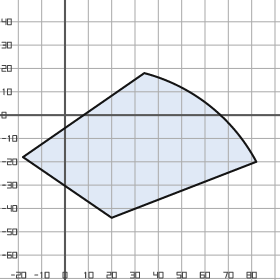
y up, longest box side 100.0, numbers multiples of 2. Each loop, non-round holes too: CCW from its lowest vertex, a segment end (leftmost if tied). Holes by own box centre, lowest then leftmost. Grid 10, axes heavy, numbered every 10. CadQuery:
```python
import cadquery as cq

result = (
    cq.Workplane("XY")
    .moveTo(20.0, -44.0)
    .lineTo(82.0, -20.0)
    .threePointArc((62.0, 4.0), (34.0, 18.0))
    .lineTo(-18.0, -18.0)
    .close()
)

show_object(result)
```